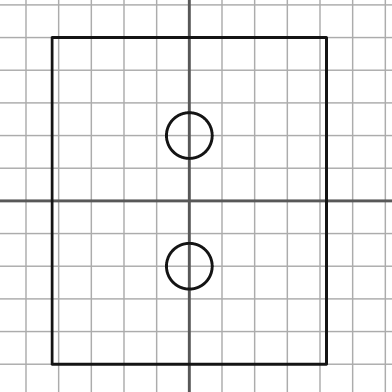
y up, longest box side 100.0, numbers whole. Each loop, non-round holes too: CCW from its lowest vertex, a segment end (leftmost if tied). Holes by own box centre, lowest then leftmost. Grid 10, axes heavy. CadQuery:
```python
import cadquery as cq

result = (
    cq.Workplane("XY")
    .moveTo(-42.0, -50.0)
    .lineTo(42.0, -50.0)
    .lineTo(42.0, 50.0)
    .lineTo(-42.0, 50.0)
    .close()
    .moveTo(0.0, -20.0)
    .circle(7.0)
    .moveTo(0.0, 20.0)
    .circle(7.0)
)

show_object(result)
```